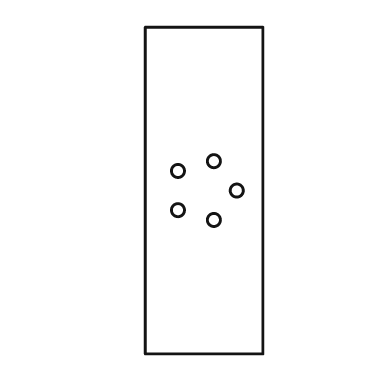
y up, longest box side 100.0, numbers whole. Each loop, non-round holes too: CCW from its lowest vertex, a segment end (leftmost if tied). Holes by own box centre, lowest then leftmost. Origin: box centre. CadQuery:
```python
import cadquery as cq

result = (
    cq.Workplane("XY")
    .moveTo(-18.0, -50.0)
    .lineTo(18.0, -50.0)
    .lineTo(18.0, 50.0)
    .lineTo(-18.0, 50.0)
    .close()
    .moveTo(3.0, -9.0)
    .circle(2.0)
    .moveTo(-8.0, -6.0)
    .circle(2.0)
    .moveTo(10.0, 0.0)
    .circle(2.0)
    .moveTo(-8.0, 6.0)
    .circle(2.0)
    .moveTo(3.0, 9.0)
    .circle(2.0)
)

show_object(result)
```